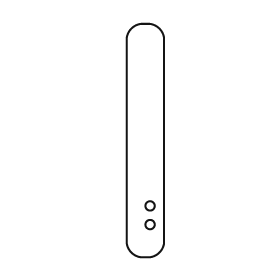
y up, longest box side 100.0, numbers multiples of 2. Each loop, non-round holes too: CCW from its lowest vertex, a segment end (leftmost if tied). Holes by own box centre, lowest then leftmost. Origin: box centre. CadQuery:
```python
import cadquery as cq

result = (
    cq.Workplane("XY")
    .moveTo(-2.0, -50.0)
    .lineTo(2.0, -50.0)
    .threePointArc((6.0, -48.0), (8.0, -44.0))
    .lineTo(8.0, 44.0)
    .threePointArc((6.0, 48.0), (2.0, 50.0))
    .lineTo(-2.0, 50.0)
    .threePointArc((-6.0, 48.0), (-8.0, 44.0))
    .lineTo(-8.0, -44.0)
    .threePointArc((-6.0, -48.0), (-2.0, -50.0))
    .close()
    .moveTo(2.0, -36.0)
    .circle(2.0)
    .moveTo(2.0, -28.0)
    .circle(2.0)
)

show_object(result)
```